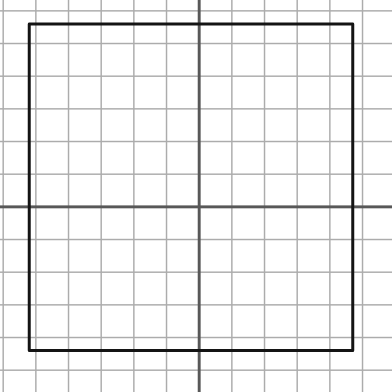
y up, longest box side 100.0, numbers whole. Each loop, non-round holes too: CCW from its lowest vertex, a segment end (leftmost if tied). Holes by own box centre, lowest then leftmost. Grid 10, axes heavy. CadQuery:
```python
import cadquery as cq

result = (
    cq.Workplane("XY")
    .moveTo(-52.0, -44.0)
    .lineTo(47.0, -44.0)
    .lineTo(47.0, 56.0)
    .lineTo(-52.0, 56.0)
    .close()
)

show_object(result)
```